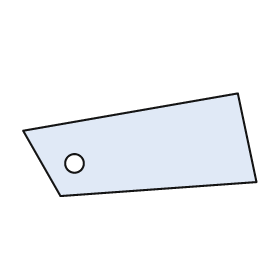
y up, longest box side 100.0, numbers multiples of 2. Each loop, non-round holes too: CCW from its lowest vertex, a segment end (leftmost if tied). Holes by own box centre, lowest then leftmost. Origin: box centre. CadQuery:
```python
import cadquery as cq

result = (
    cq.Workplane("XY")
    .moveTo(-34.0, -22.0)
    .lineTo(50.0, -16.0)
    .lineTo(42.0, 22.0)
    .lineTo(-50.0, 6.0)
    .close()
    .moveTo(-28.0, -8.0)
    .circle(4.0)
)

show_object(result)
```